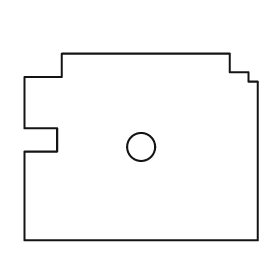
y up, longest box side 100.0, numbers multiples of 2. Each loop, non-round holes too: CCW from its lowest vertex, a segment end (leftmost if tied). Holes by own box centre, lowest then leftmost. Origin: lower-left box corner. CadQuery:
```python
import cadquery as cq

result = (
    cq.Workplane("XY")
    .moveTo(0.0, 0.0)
    .lineTo(100.0, 0.0)
    .lineTo(100.0, 68.0)
    .lineTo(96.0, 68.0)
    .lineTo(96.0, 72.0)
    .lineTo(88.0, 72.0)
    .lineTo(88.0, 80.0)
    .lineTo(16.0, 80.0)
    .lineTo(16.0, 70.0)
    .lineTo(0.0, 70.0)
    .lineTo(0.0, 48.0)
    .lineTo(14.0, 48.0)
    .lineTo(14.0, 38.0)
    .lineTo(0.0, 38.0)
    .close()
    .moveTo(50.0, 40.0)
    .circle(6.0)
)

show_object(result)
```